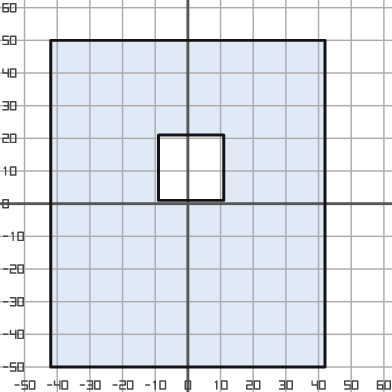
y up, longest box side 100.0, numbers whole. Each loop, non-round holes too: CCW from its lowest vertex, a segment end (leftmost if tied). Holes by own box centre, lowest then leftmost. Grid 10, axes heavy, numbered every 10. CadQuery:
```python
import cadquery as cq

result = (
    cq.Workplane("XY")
    .moveTo(-42.0, -50.0)
    .lineTo(42.0, -50.0)
    .lineTo(42.0, 50.0)
    .lineTo(-42.0, 50.0)
    .close()
    .moveTo(-9.0, 1.0)
    .lineTo(11.0, 1.0)
    .lineTo(11.0, 21.0)
    .lineTo(-9.0, 21.0)
    .close()
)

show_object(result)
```